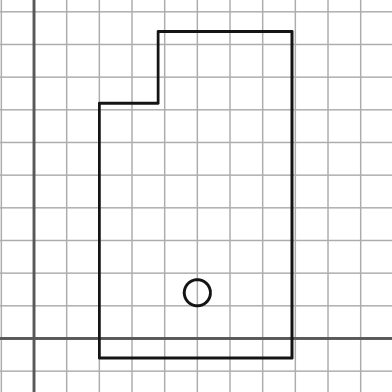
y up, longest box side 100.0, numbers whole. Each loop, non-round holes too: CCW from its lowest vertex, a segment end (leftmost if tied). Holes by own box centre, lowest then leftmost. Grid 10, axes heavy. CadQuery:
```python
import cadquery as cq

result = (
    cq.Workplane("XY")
    .moveTo(20.0, -6.0)
    .lineTo(79.0, -6.0)
    .lineTo(79.0, 94.0)
    .lineTo(38.0, 94.0)
    .lineTo(38.0, 72.0)
    .lineTo(20.0, 72.0)
    .close()
    .moveTo(50.0, 14.0)
    .circle(4.0)
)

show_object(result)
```